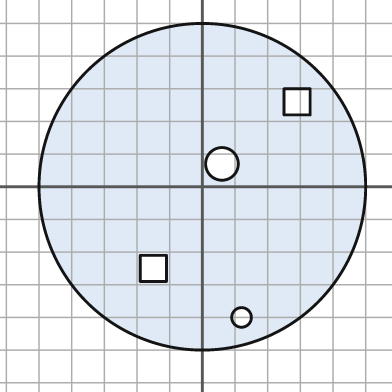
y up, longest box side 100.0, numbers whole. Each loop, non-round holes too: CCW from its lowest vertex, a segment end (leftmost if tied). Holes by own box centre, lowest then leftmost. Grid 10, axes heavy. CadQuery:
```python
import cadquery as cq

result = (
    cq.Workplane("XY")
    .moveTo(0.0, 0.0)
    .circle(50.0)
    .moveTo(12.0, -40.0)
    .circle(3.0)
    .moveTo(-19.0, -29.0)
    .lineTo(-11.0, -29.0)
    .lineTo(-11.0, -21.0)
    .lineTo(-19.0, -21.0)
    .close()
    .moveTo(6.0, 7.0)
    .circle(5.0)
    .moveTo(25.0, 22.0)
    .lineTo(33.0, 22.0)
    .lineTo(33.0, 30.0)
    .lineTo(25.0, 30.0)
    .close()
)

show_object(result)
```